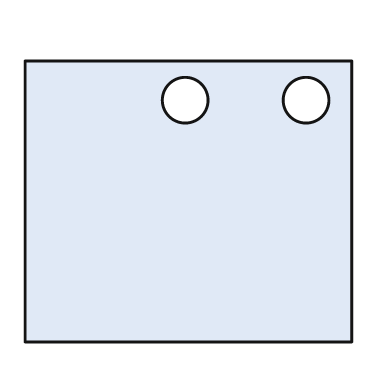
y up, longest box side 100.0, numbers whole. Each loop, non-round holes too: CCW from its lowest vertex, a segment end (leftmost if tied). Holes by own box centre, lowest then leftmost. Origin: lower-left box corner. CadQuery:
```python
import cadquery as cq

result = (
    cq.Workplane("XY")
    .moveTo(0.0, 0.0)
    .lineTo(100.0, 0.0)
    .lineTo(100.0, 86.0)
    .lineTo(0.0, 86.0)
    .close()
    .moveTo(49.0, 74.0)
    .circle(7.0)
    .moveTo(86.0, 74.0)
    .circle(7.0)
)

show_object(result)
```